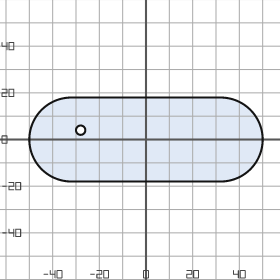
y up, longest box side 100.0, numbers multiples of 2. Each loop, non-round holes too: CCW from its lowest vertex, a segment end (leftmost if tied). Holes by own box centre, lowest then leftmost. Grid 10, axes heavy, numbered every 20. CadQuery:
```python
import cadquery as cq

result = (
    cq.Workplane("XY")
    .moveTo(-32.0, -18.0)
    .lineTo(32.0, -18.0)
    .threePointArc((50.0, 0.0), (32.0, 18.0))
    .lineTo(-32.0, 18.0)
    .threePointArc((-50.0, 0.0), (-32.0, -18.0))
    .close()
    .moveTo(-28.0, 4.0)
    .circle(2.0)
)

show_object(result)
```